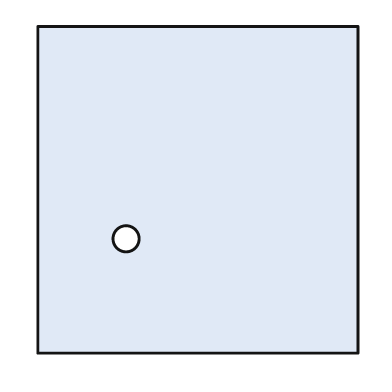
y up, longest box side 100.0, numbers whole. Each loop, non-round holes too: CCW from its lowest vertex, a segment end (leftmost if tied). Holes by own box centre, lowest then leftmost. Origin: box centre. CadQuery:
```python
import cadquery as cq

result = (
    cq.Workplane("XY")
    .moveTo(-49.0, -50.0)
    .lineTo(49.0, -50.0)
    .lineTo(49.0, 50.0)
    .lineTo(-49.0, 50.0)
    .close()
    .moveTo(-22.0, -15.0)
    .circle(4.0)
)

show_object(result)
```